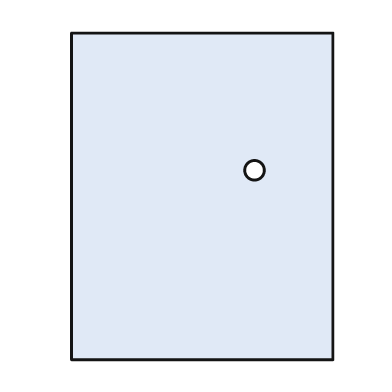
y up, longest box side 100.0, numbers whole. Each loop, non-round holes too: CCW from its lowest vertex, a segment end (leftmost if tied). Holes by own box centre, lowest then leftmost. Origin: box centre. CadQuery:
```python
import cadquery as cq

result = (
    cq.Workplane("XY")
    .moveTo(-40.0, -50.0)
    .lineTo(40.0, -50.0)
    .lineTo(40.0, 50.0)
    .lineTo(-40.0, 50.0)
    .close()
    .moveTo(16.0, 8.0)
    .circle(3.0)
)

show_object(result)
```